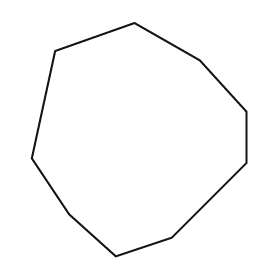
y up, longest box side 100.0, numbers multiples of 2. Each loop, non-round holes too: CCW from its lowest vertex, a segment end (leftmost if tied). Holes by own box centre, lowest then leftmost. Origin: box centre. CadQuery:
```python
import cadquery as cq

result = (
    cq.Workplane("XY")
    .moveTo(-10.0, -50.0)
    .lineTo(14.0, -42.0)
    .lineTo(46.0, -10.0)
    .lineTo(46.0, 12.0)
    .lineTo(26.0, 34.0)
    .lineTo(-2.0, 50.0)
    .lineTo(-36.0, 38.0)
    .lineTo(-46.0, -8.0)
    .lineTo(-30.0, -32.0)
    .close()
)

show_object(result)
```